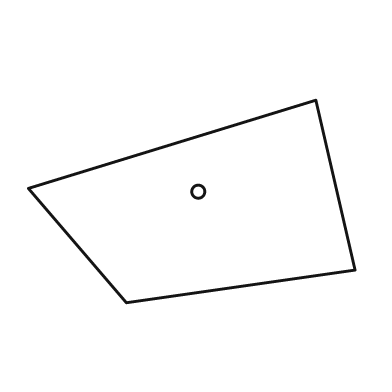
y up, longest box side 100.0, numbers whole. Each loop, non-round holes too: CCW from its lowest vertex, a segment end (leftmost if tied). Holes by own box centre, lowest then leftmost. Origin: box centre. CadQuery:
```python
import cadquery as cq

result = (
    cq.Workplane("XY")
    .moveTo(-20.0, -31.0)
    .lineTo(50.0, -21.0)
    .lineTo(38.0, 31.0)
    .lineTo(-50.0, 4.0)
    .close()
    .moveTo(2.0, 3.0)
    .circle(2.0)
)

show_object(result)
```